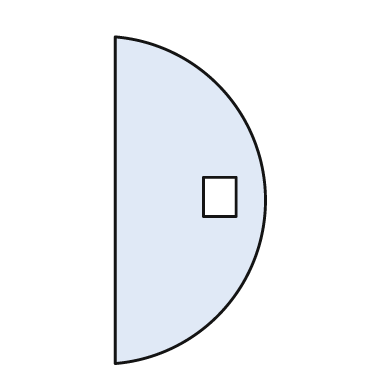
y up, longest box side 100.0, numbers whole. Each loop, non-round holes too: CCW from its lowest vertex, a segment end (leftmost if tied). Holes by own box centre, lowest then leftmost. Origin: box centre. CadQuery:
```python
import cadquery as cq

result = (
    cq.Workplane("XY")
    .moveTo(-23.0, -50.0)
    .threePointArc((23.0, 0.0), (-23.0, 50.0))
    .close()
    .moveTo(4.0, -5.0)
    .lineTo(14.0, -5.0)
    .lineTo(14.0, 7.0)
    .lineTo(4.0, 7.0)
    .close()
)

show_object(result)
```